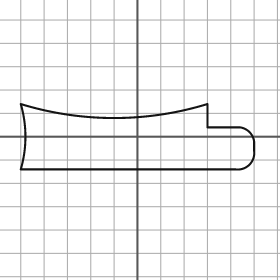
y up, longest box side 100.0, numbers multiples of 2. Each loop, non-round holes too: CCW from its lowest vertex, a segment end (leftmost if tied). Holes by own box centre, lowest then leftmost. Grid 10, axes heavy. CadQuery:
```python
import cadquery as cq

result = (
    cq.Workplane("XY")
    .moveTo(-50.0, -14.0)
    .lineTo(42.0, -14.0)
    .threePointArc((48.0, -12.0), (50.0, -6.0))
    .lineTo(50.0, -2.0)
    .threePointArc((48.0, 2.0), (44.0, 4.0))
    .lineTo(30.0, 4.0)
    .lineTo(30.0, 14.0)
    .threePointArc((-10.0, 8.0), (-50.0, 14.0))
    .threePointArc((-48.0, 0.0), (-50.0, -14.0))
    .close()
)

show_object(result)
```